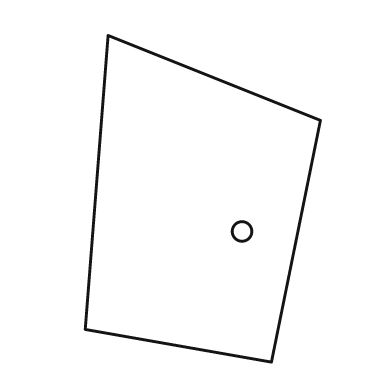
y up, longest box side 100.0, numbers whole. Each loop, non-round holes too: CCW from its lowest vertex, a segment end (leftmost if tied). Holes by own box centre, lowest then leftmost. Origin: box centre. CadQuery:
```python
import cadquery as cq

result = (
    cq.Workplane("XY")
    .moveTo(21.0, -50.0)
    .lineTo(36.0, 24.0)
    .lineTo(-29.0, 50.0)
    .lineTo(-36.0, -40.0)
    .close()
    .moveTo(12.0, -10.0)
    .circle(3.0)
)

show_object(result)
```